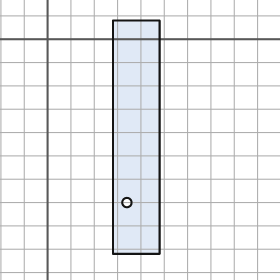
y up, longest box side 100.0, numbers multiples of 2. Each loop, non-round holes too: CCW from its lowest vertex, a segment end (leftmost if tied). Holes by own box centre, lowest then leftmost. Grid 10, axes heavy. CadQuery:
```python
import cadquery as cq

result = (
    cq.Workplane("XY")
    .moveTo(28.0, -92.0)
    .lineTo(48.0, -92.0)
    .lineTo(48.0, 8.0)
    .lineTo(28.0, 8.0)
    .close()
    .moveTo(34.0, -70.0)
    .circle(2.0)
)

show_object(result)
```